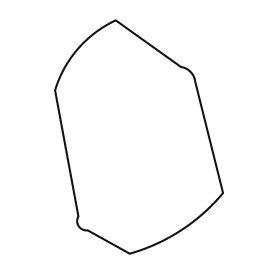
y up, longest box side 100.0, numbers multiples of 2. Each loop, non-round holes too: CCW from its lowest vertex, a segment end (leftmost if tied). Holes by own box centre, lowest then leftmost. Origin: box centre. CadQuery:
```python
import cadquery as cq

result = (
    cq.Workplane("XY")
    .moveTo(-4.0, -50.0)
    .threePointArc((18.0, -40.0), (36.0, -24.0))
    .lineTo(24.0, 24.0)
    .threePointArc((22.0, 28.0), (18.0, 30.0))
    .lineTo(-10.0, 50.0)
    .threePointArc((-26.0, 38.0), (-36.0, 20.0))
    .lineTo(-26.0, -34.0)
    .threePointArc((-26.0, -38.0), (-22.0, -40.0))
    .close()
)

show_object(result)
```